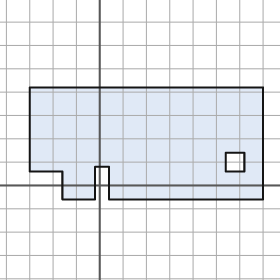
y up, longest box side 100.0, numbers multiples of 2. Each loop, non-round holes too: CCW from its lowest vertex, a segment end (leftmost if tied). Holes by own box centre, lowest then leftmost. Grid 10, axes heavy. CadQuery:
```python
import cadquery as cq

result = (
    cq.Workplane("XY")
    .moveTo(-16.0, -6.0)
    .lineTo(-2.0, -6.0)
    .lineTo(-2.0, 8.0)
    .lineTo(4.0, 8.0)
    .lineTo(4.0, -6.0)
    .lineTo(70.0, -6.0)
    .lineTo(70.0, 42.0)
    .lineTo(-30.0, 42.0)
    .lineTo(-30.0, 6.0)
    .lineTo(-16.0, 6.0)
    .close()
    .moveTo(54.0, 6.0)
    .lineTo(62.0, 6.0)
    .lineTo(62.0, 14.0)
    .lineTo(54.0, 14.0)
    .close()
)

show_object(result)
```